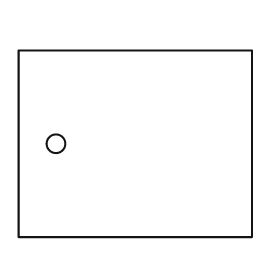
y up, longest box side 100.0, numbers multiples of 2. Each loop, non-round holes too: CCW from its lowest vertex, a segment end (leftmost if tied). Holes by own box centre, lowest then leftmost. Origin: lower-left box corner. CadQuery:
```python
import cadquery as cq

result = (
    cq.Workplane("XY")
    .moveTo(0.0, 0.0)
    .lineTo(100.0, 0.0)
    .lineTo(100.0, 80.0)
    .lineTo(0.0, 80.0)
    .close()
    .moveTo(16.0, 40.0)
    .circle(4.0)
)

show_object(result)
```